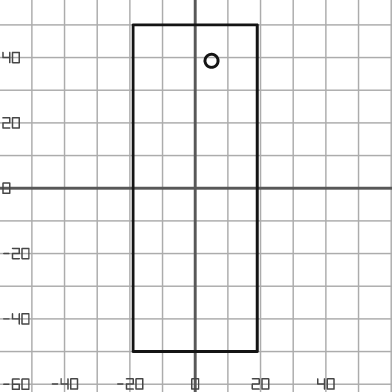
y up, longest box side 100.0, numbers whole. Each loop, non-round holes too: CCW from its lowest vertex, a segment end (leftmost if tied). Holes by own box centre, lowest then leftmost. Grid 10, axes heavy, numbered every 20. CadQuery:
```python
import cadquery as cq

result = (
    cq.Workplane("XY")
    .moveTo(-19.0, -50.0)
    .lineTo(19.0, -50.0)
    .lineTo(19.0, 50.0)
    .lineTo(-19.0, 50.0)
    .close()
    .moveTo(5.0, 39.0)
    .circle(2.0)
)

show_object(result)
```